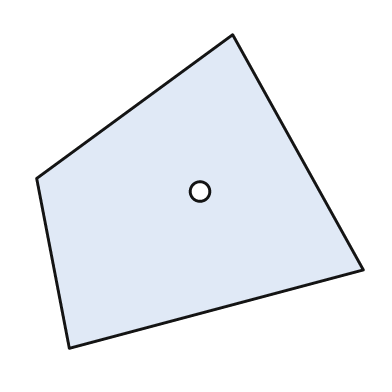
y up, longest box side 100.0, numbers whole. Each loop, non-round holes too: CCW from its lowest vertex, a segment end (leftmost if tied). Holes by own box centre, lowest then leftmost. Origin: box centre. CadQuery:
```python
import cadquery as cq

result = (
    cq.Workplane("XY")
    .moveTo(-40.0, -48.0)
    .lineTo(50.0, -24.0)
    .lineTo(10.0, 48.0)
    .lineTo(-50.0, 4.0)
    .close()
    .moveTo(0.0, 0.0)
    .circle(3.0)
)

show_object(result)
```